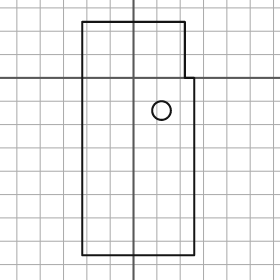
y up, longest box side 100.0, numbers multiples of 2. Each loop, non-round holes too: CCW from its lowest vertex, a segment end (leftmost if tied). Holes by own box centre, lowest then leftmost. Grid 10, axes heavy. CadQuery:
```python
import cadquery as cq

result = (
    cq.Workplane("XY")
    .moveTo(-22.0, -76.0)
    .lineTo(26.0, -76.0)
    .lineTo(26.0, 0.0)
    .lineTo(22.0, 0.0)
    .lineTo(22.0, 24.0)
    .lineTo(-22.0, 24.0)
    .close()
    .moveTo(12.0, -14.0)
    .circle(4.0)
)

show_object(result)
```